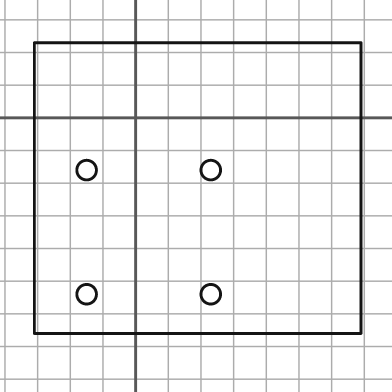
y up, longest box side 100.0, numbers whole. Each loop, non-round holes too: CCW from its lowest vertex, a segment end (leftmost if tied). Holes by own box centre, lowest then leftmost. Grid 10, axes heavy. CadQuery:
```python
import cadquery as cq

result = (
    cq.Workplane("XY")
    .moveTo(-31.0, -66.0)
    .lineTo(69.0, -66.0)
    .lineTo(69.0, 23.0)
    .lineTo(-31.0, 23.0)
    .close()
    .moveTo(-15.0, -54.0)
    .circle(3.0)
    .moveTo(23.0, -54.0)
    .circle(3.0)
    .moveTo(-15.0, -16.0)
    .circle(3.0)
    .moveTo(23.0, -16.0)
    .circle(3.0)
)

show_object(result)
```